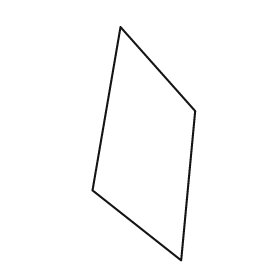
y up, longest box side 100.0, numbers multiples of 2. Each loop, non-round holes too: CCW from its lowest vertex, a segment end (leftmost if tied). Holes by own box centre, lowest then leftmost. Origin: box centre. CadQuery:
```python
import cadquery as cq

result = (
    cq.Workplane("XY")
    .moveTo(16.0, -50.0)
    .lineTo(22.0, 14.0)
    .lineTo(-10.0, 50.0)
    .lineTo(-22.0, -20.0)
    .close()
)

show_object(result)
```